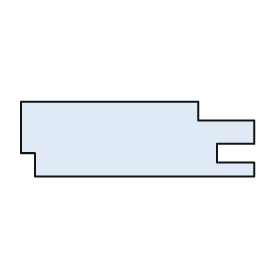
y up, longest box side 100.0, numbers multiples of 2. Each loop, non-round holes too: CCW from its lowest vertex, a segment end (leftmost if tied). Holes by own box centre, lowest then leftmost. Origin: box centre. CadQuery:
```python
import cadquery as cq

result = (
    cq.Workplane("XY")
    .moveTo(-44.0, -16.0)
    .lineTo(50.0, -16.0)
    .lineTo(50.0, -10.0)
    .lineTo(34.0, -10.0)
    .lineTo(34.0, -2.0)
    .lineTo(50.0, -2.0)
    .lineTo(50.0, 8.0)
    .lineTo(26.0, 8.0)
    .lineTo(26.0, 16.0)
    .lineTo(-50.0, 16.0)
    .lineTo(-50.0, -6.0)
    .lineTo(-44.0, -6.0)
    .close()
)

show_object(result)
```